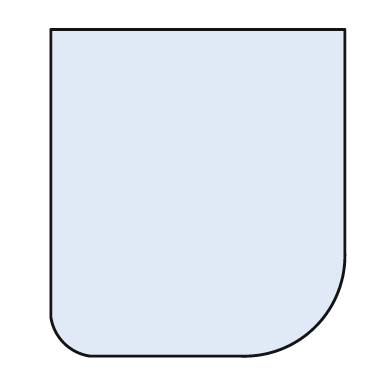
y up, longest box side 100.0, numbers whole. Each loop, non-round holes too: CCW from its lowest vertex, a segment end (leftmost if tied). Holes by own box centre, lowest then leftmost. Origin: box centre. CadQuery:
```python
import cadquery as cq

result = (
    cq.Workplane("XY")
    .moveTo(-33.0, -50.0)
    .lineTo(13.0, -50.0)
    .threePointArc((36.0, -41.0), (45.0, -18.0))
    .lineTo(45.0, 50.0)
    .lineTo(-45.0, 50.0)
    .lineTo(-45.0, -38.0)
    .threePointArc((-41.0, -46.0), (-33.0, -50.0))
    .close()
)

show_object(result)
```